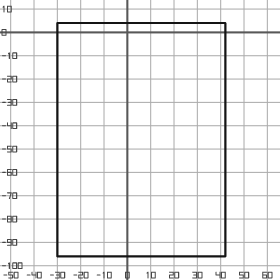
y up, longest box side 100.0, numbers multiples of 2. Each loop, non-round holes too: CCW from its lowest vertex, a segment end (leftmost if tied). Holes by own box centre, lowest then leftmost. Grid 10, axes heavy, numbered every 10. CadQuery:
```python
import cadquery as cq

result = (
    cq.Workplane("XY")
    .moveTo(-30.0, -96.0)
    .lineTo(42.0, -96.0)
    .lineTo(42.0, 4.0)
    .lineTo(-30.0, 4.0)
    .close()
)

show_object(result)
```